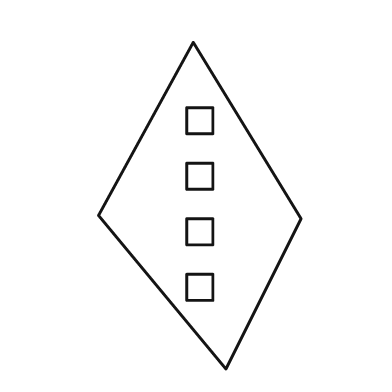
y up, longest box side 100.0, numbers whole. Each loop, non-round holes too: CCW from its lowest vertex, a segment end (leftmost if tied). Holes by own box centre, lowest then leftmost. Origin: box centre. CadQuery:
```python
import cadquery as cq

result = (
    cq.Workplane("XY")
    .moveTo(8.0, -50.0)
    .lineTo(31.0, -4.0)
    .lineTo(-2.0, 50.0)
    .lineTo(-31.0, -3.0)
    .close()
    .moveTo(-4.0, -29.0)
    .lineTo(4.0, -29.0)
    .lineTo(4.0, -21.0)
    .lineTo(-4.0, -21.0)
    .close()
    .moveTo(-4.0, -12.0)
    .lineTo(4.0, -12.0)
    .lineTo(4.0, -4.0)
    .lineTo(-4.0, -4.0)
    .close()
    .moveTo(-4.0, 5.0)
    .lineTo(4.0, 5.0)
    .lineTo(4.0, 13.0)
    .lineTo(-4.0, 13.0)
    .close()
    .moveTo(-4.0, 22.0)
    .lineTo(4.0, 22.0)
    .lineTo(4.0, 30.0)
    .lineTo(-4.0, 30.0)
    .close()
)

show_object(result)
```